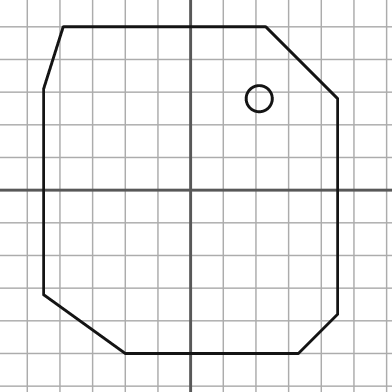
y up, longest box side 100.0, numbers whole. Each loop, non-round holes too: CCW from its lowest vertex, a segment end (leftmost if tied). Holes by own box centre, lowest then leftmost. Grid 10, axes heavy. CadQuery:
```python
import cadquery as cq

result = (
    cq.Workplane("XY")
    .moveTo(-20.0, -50.0)
    .lineTo(33.0, -50.0)
    .lineTo(45.0, -38.0)
    .lineTo(45.0, 28.0)
    .lineTo(23.0, 50.0)
    .lineTo(-39.0, 50.0)
    .lineTo(-45.0, 31.0)
    .lineTo(-45.0, -32.0)
    .close()
    .moveTo(21.0, 28.0)
    .circle(4.0)
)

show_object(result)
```